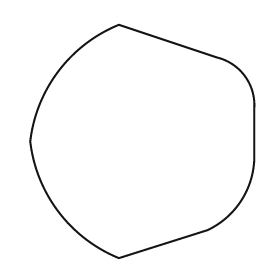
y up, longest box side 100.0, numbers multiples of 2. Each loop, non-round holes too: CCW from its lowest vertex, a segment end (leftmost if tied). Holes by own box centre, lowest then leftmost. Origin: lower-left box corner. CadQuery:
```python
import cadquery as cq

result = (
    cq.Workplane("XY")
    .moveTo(38.0, 0.0)
    .lineTo(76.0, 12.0)
    .threePointArc((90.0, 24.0), (96.0, 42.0))
    .lineTo(96.0, 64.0)
    .threePointArc((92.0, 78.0), (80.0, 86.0))
    .lineTo(38.0, 100.0)
    .threePointArc((12.0, 80.0), (0.0, 50.0))
    .threePointArc((12.0, 20.0), (38.0, 0.0))
    .close()
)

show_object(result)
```